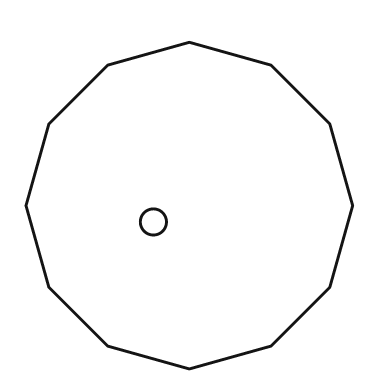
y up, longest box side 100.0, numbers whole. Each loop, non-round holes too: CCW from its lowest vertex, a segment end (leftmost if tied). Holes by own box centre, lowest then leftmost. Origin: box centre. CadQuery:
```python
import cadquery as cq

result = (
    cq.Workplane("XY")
    .moveTo(0.0, -50.0)
    .lineTo(25.0, -43.0)
    .lineTo(43.0, -25.0)
    .lineTo(50.0, 0.0)
    .lineTo(43.0, 25.0)
    .lineTo(25.0, 43.0)
    .lineTo(0.0, 50.0)
    .lineTo(-25.0, 43.0)
    .lineTo(-43.0, 25.0)
    .lineTo(-50.0, 0.0)
    .lineTo(-43.0, -25.0)
    .lineTo(-25.0, -43.0)
    .close()
    .moveTo(-11.0, -5.0)
    .circle(4.0)
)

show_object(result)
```